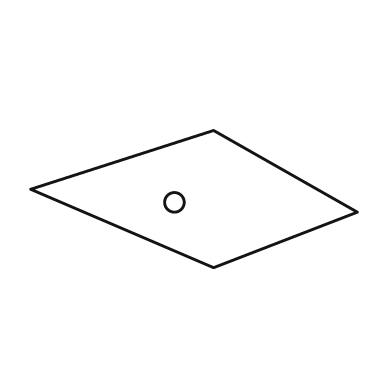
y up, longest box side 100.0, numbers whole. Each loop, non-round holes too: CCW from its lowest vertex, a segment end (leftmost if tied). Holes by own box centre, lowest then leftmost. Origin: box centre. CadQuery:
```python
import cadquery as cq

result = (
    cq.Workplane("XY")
    .moveTo(6.0, -21.0)
    .lineTo(50.0, -4.0)
    .lineTo(6.0, 21.0)
    .lineTo(-50.0, 3.0)
    .close()
    .moveTo(-6.0, -1.0)
    .circle(3.0)
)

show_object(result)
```